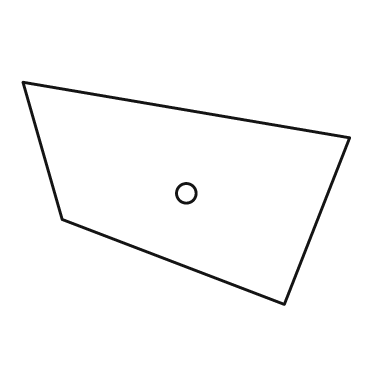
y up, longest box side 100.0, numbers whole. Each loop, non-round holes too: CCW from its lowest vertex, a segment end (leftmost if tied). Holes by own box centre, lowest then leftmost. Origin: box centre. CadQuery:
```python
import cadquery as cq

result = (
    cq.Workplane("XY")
    .moveTo(30.0, -34.0)
    .lineTo(50.0, 17.0)
    .lineTo(-50.0, 34.0)
    .lineTo(-38.0, -8.0)
    .close()
    .moveTo(0.0, 0.0)
    .circle(3.0)
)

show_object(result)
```